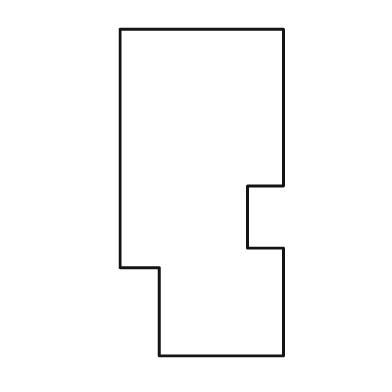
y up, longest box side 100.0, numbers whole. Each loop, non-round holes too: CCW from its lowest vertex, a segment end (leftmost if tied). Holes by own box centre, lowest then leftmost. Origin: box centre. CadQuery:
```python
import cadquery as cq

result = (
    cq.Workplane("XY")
    .moveTo(-13.0, -50.0)
    .lineTo(25.0, -50.0)
    .lineTo(25.0, -17.0)
    .lineTo(14.0, -17.0)
    .lineTo(14.0, 2.0)
    .lineTo(25.0, 2.0)
    .lineTo(25.0, 50.0)
    .lineTo(-25.0, 50.0)
    .lineTo(-25.0, -23.0)
    .lineTo(-13.0, -23.0)
    .close()
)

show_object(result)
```